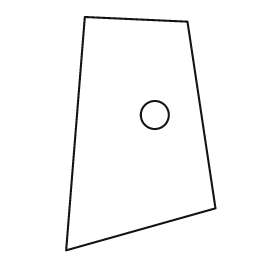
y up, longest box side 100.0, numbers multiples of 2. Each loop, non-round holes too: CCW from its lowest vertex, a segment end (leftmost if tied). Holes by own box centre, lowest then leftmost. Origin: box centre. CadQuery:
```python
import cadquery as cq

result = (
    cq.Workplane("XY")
    .moveTo(-32.0, -50.0)
    .lineTo(32.0, -32.0)
    .lineTo(20.0, 48.0)
    .lineTo(-24.0, 50.0)
    .close()
    .moveTo(6.0, 8.0)
    .circle(6.0)
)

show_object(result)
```